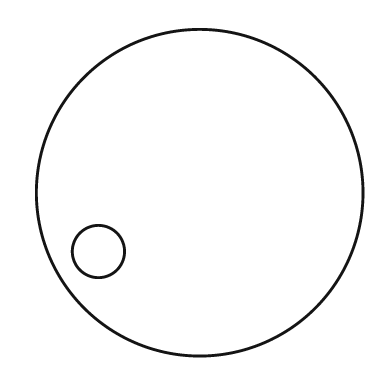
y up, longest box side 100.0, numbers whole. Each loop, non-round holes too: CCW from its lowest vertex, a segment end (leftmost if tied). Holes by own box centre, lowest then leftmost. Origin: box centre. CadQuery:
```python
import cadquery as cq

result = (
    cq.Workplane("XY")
    .moveTo(0.0, 0.0)
    .circle(50.0)
    .moveTo(-31.0, -18.0)
    .circle(8.0)
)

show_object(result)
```